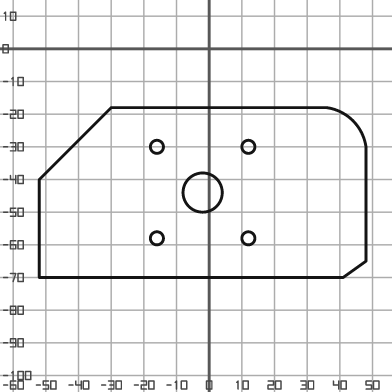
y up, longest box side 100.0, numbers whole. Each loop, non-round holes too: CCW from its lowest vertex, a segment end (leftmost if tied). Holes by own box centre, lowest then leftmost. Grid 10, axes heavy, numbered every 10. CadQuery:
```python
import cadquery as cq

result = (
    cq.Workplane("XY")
    .moveTo(-52.0, -70.0)
    .lineTo(41.0, -70.0)
    .lineTo(48.0, -65.0)
    .lineTo(48.0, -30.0)
    .threePointArc((44.0, -22.0), (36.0, -18.0))
    .lineTo(-30.0, -18.0)
    .lineTo(-52.0, -40.0)
    .close()
    .moveTo(-16.0, -58.0)
    .circle(2.0)
    .moveTo(12.0, -58.0)
    .circle(2.0)
    .moveTo(-2.0, -44.0)
    .circle(6.0)
    .moveTo(-16.0, -30.0)
    .circle(2.0)
    .moveTo(12.0, -30.0)
    .circle(2.0)
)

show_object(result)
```